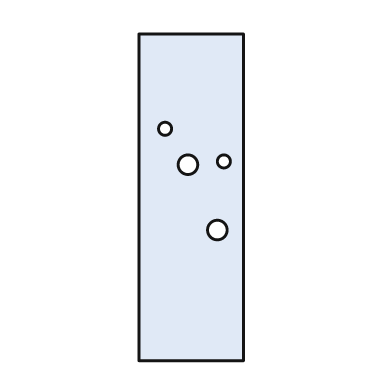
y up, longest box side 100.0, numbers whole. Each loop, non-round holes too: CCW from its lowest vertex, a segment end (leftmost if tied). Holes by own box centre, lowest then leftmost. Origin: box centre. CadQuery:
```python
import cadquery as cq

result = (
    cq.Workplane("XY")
    .moveTo(-16.0, -50.0)
    .lineTo(16.0, -50.0)
    .lineTo(16.0, 50.0)
    .lineTo(-16.0, 50.0)
    .close()
    .moveTo(8.0, -10.0)
    .circle(3.0)
    .moveTo(-1.0, 10.0)
    .circle(3.0)
    .moveTo(10.0, 11.0)
    .circle(2.0)
    .moveTo(-8.0, 21.0)
    .circle(2.0)
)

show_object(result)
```